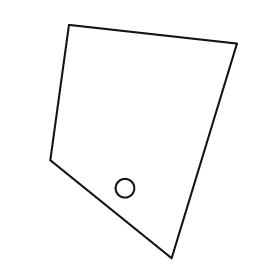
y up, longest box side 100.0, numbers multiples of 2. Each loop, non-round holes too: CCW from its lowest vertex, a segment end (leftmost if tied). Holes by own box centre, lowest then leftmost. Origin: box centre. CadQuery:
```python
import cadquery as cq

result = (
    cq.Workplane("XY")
    .moveTo(12.0, -50.0)
    .lineTo(40.0, 42.0)
    .lineTo(-32.0, 50.0)
    .lineTo(-40.0, -8.0)
    .close()
    .moveTo(-8.0, -20.0)
    .circle(4.0)
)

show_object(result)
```